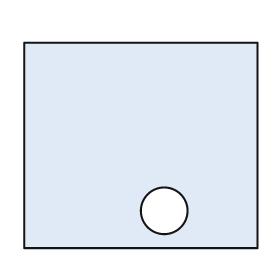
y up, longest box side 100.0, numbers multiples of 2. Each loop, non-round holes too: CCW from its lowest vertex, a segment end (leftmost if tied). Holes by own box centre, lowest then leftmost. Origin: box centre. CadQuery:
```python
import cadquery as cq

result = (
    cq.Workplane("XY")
    .moveTo(-50.0, -44.0)
    .lineTo(50.0, -44.0)
    .lineTo(50.0, 44.0)
    .lineTo(-50.0, 44.0)
    .close()
    .moveTo(10.0, -28.0)
    .circle(10.0)
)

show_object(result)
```